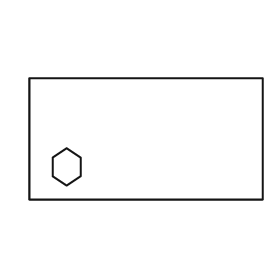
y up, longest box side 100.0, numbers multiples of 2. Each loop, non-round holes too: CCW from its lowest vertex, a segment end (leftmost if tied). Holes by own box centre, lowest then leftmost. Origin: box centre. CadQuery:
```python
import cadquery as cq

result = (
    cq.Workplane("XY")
    .moveTo(-50.0, -26.0)
    .lineTo(50.0, -26.0)
    .lineTo(50.0, 26.0)
    .lineTo(-50.0, 26.0)
    .close()
    .moveTo(-34.0, -20.0)
    .lineTo(-28.0, -16.0)
    .lineTo(-28.0, -8.0)
    .lineTo(-34.0, -4.0)
    .lineTo(-40.0, -8.0)
    .lineTo(-40.0, -16.0)
    .close()
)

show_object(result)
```